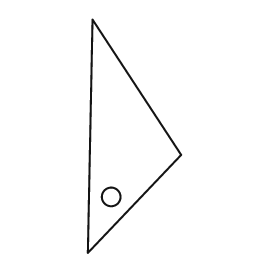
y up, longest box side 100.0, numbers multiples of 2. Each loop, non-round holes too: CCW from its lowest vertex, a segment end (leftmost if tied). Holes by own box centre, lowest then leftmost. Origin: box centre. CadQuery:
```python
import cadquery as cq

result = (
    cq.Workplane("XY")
    .moveTo(-20.0, -50.0)
    .lineTo(20.0, -8.0)
    .lineTo(-18.0, 50.0)
    .close()
    .moveTo(-10.0, -26.0)
    .circle(4.0)
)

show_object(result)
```